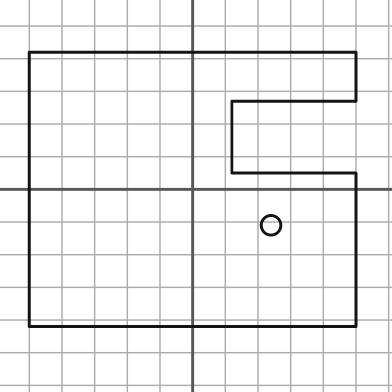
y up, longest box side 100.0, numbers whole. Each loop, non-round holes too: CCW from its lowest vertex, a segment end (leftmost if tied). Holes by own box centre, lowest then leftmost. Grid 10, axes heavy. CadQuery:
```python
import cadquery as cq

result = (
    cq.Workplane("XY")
    .moveTo(-50.0, -42.0)
    .lineTo(50.0, -42.0)
    .lineTo(50.0, 5.0)
    .lineTo(12.0, 5.0)
    .lineTo(12.0, 27.0)
    .lineTo(50.0, 27.0)
    .lineTo(50.0, 42.0)
    .lineTo(-50.0, 42.0)
    .close()
    .moveTo(24.0, -11.0)
    .circle(3.0)
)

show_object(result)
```